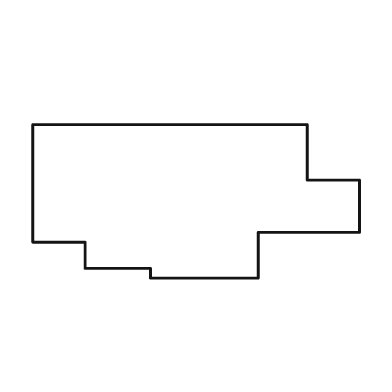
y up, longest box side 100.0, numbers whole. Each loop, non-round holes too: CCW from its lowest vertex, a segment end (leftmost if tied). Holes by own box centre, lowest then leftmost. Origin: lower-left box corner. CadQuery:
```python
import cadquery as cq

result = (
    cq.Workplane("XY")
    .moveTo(36.0, 0.0)
    .lineTo(69.0, 0.0)
    .lineTo(69.0, 14.0)
    .lineTo(100.0, 14.0)
    .lineTo(100.0, 30.0)
    .lineTo(84.0, 30.0)
    .lineTo(84.0, 47.0)
    .lineTo(0.0, 47.0)
    .lineTo(0.0, 11.0)
    .lineTo(16.0, 11.0)
    .lineTo(16.0, 3.0)
    .lineTo(36.0, 3.0)
    .close()
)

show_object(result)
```